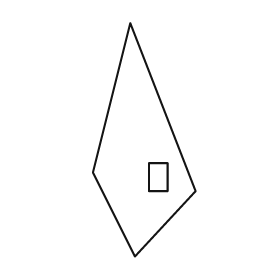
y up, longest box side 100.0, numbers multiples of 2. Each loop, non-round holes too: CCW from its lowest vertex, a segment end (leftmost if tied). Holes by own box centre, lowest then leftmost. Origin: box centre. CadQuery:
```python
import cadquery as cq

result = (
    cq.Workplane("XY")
    .moveTo(-4.0, -50.0)
    .lineTo(22.0, -22.0)
    .lineTo(-6.0, 50.0)
    .lineTo(-22.0, -14.0)
    .close()
    .moveTo(2.0, -22.0)
    .lineTo(10.0, -22.0)
    .lineTo(10.0, -10.0)
    .lineTo(2.0, -10.0)
    .close()
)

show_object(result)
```